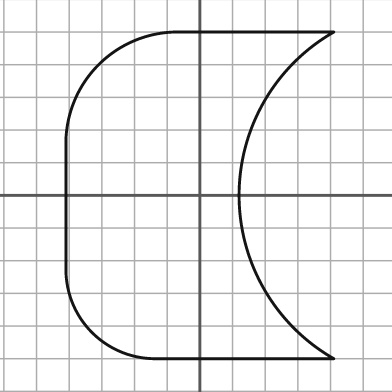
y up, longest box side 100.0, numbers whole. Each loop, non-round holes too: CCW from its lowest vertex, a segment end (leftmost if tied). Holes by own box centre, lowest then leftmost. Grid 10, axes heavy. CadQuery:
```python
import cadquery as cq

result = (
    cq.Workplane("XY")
    .moveTo(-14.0, -50.0)
    .lineTo(41.0, -50.0)
    .threePointArc((12.0, 0.0), (41.0, 50.0))
    .lineTo(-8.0, 50.0)
    .threePointArc((-31.0, 40.0), (-41.0, 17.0))
    .lineTo(-41.0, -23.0)
    .threePointArc((-33.0, -42.0), (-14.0, -50.0))
    .close()
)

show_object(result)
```